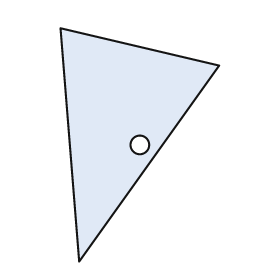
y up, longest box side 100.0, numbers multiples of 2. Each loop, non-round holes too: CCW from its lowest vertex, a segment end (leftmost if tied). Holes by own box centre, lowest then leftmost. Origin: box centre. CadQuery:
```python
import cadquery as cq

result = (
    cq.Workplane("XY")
    .moveTo(-26.0, -50.0)
    .lineTo(34.0, 34.0)
    .lineTo(-34.0, 50.0)
    .close()
    .moveTo(0.0, 0.0)
    .circle(4.0)
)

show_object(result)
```